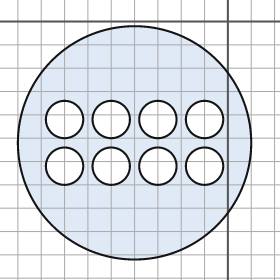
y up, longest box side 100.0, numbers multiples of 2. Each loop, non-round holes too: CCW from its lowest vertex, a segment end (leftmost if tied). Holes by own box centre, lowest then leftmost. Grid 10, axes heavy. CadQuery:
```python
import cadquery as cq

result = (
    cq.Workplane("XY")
    .moveTo(-40.0, -52.0)
    .circle(50.0)
    .moveTo(-70.0, -62.0)
    .circle(8.0)
    .moveTo(-50.0, -62.0)
    .circle(8.0)
    .moveTo(-30.0, -62.0)
    .circle(8.0)
    .moveTo(-10.0, -62.0)
    .circle(8.0)
    .moveTo(-70.0, -42.0)
    .circle(8.0)
    .moveTo(-50.0, -42.0)
    .circle(8.0)
    .moveTo(-30.0, -42.0)
    .circle(8.0)
    .moveTo(-10.0, -42.0)
    .circle(8.0)
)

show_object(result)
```